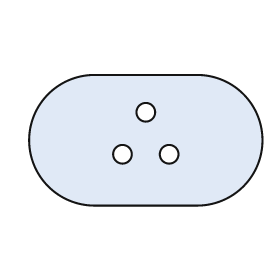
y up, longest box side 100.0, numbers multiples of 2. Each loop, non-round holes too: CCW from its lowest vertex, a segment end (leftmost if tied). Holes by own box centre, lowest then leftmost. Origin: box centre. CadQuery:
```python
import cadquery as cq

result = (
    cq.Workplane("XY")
    .moveTo(-22.0, -28.0)
    .lineTo(22.0, -28.0)
    .threePointArc((50.0, 0.0), (22.0, 28.0))
    .lineTo(-22.0, 28.0)
    .threePointArc((-50.0, 0.0), (-22.0, -28.0))
    .close()
    .moveTo(-10.0, -6.0)
    .circle(4.0)
    .moveTo(10.0, -6.0)
    .circle(4.0)
    .moveTo(0.0, 12.0)
    .circle(4.0)
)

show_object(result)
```